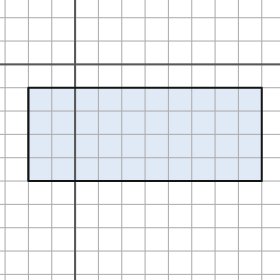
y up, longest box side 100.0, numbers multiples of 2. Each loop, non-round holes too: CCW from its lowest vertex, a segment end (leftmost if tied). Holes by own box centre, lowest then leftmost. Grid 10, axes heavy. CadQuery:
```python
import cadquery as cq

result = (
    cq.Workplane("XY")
    .moveTo(-20.0, -50.0)
    .lineTo(80.0, -50.0)
    .lineTo(80.0, -10.0)
    .lineTo(-20.0, -10.0)
    .close()
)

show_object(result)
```